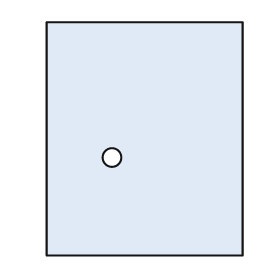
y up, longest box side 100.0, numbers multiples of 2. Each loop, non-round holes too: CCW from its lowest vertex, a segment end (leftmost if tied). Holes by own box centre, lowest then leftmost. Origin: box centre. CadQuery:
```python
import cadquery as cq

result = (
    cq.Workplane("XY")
    .moveTo(-42.0, -50.0)
    .lineTo(42.0, -50.0)
    .lineTo(42.0, 50.0)
    .lineTo(-42.0, 50.0)
    .close()
    .moveTo(-14.0, -8.0)
    .circle(4.0)
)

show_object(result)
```